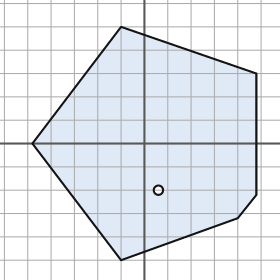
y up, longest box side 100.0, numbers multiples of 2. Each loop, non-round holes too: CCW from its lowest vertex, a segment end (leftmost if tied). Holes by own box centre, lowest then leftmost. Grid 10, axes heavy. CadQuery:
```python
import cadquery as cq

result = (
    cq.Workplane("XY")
    .moveTo(-10.0, -50.0)
    .lineTo(40.0, -32.0)
    .lineTo(48.0, -22.0)
    .lineTo(48.0, 30.0)
    .lineTo(-10.0, 50.0)
    .lineTo(-48.0, 0.0)
    .close()
    .moveTo(6.0, -20.0)
    .circle(2.0)
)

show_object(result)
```